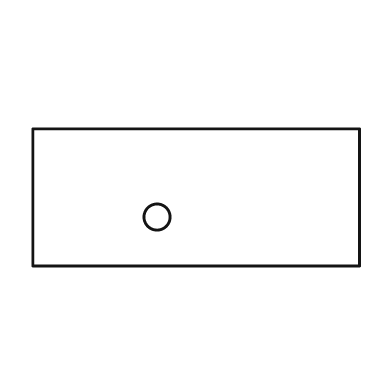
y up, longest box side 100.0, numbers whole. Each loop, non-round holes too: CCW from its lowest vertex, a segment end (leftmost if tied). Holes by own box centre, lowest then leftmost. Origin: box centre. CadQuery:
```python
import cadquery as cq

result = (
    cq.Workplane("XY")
    .moveTo(-50.0, -21.0)
    .lineTo(50.0, -21.0)
    .lineTo(50.0, 21.0)
    .lineTo(-50.0, 21.0)
    .close()
    .moveTo(-12.0, -6.0)
    .circle(4.0)
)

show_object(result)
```